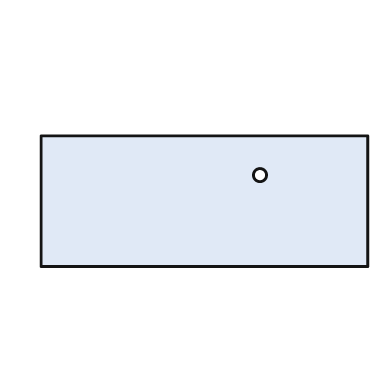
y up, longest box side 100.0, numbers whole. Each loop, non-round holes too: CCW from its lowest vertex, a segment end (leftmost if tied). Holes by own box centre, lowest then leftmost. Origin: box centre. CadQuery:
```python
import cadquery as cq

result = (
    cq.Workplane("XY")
    .moveTo(-50.0, -20.0)
    .lineTo(50.0, -20.0)
    .lineTo(50.0, 20.0)
    .lineTo(-50.0, 20.0)
    .close()
    .moveTo(17.0, 8.0)
    .circle(2.0)
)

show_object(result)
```